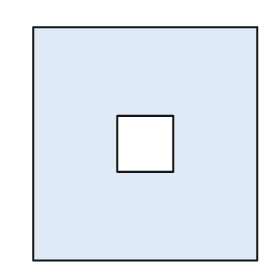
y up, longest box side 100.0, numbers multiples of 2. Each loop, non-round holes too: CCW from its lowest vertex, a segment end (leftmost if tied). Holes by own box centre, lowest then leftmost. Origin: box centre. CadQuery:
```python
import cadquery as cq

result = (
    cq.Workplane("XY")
    .moveTo(-48.0, -50.0)
    .lineTo(48.0, -50.0)
    .lineTo(48.0, 50.0)
    .lineTo(-48.0, 50.0)
    .close()
    .moveTo(-12.0, -12.0)
    .lineTo(12.0, -12.0)
    .lineTo(12.0, 12.0)
    .lineTo(-12.0, 12.0)
    .close()
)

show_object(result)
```